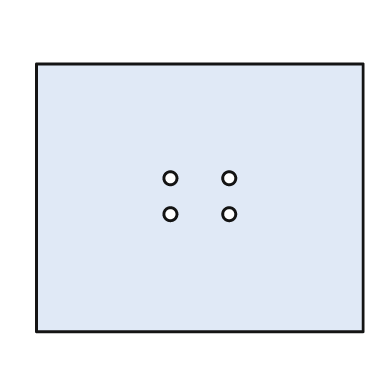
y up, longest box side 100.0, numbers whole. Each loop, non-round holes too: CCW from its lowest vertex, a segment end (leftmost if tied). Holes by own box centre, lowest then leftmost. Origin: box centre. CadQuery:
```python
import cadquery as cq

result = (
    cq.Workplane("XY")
    .moveTo(-50.0, -41.0)
    .lineTo(50.0, -41.0)
    .lineTo(50.0, 41.0)
    .lineTo(-50.0, 41.0)
    .close()
    .moveTo(-9.0, -5.0)
    .circle(2.0)
    .moveTo(9.0, -5.0)
    .circle(2.0)
    .moveTo(-9.0, 6.0)
    .circle(2.0)
    .moveTo(9.0, 6.0)
    .circle(2.0)
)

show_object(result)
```